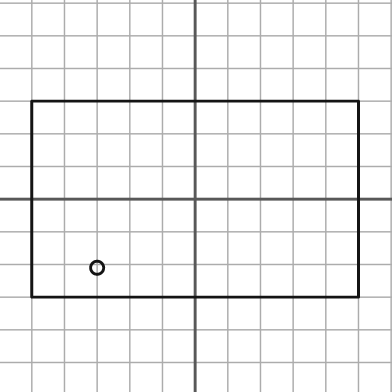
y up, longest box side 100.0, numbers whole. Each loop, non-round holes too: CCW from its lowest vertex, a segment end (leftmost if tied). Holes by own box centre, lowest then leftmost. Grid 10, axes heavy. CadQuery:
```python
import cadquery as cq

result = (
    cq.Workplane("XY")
    .moveTo(-50.0, -30.0)
    .lineTo(50.0, -30.0)
    .lineTo(50.0, 30.0)
    .lineTo(-50.0, 30.0)
    .close()
    .moveTo(-30.0, -21.0)
    .circle(2.0)
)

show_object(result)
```